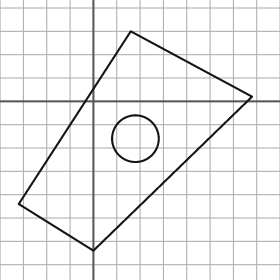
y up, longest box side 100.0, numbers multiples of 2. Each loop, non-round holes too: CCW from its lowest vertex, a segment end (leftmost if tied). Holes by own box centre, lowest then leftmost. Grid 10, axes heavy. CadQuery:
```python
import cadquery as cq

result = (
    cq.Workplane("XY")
    .moveTo(0.0, -64.0)
    .lineTo(68.0, 2.0)
    .lineTo(16.0, 30.0)
    .lineTo(-32.0, -44.0)
    .close()
    .moveTo(18.0, -16.0)
    .circle(10.0)
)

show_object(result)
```